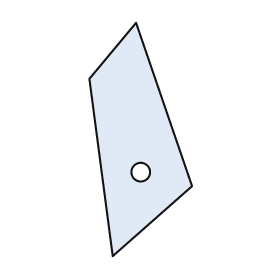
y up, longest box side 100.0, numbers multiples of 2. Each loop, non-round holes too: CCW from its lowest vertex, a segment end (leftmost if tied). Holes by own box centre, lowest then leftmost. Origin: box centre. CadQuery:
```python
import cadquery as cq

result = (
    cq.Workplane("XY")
    .moveTo(-12.0, -50.0)
    .lineTo(22.0, -20.0)
    .lineTo(-2.0, 50.0)
    .lineTo(-22.0, 26.0)
    .close()
    .moveTo(0.0, -14.0)
    .circle(4.0)
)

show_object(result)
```